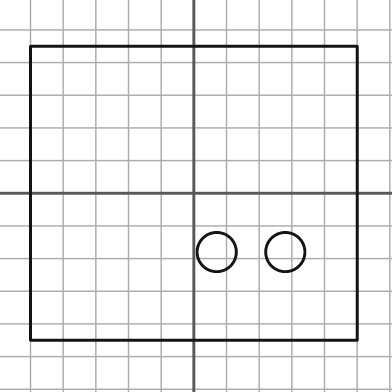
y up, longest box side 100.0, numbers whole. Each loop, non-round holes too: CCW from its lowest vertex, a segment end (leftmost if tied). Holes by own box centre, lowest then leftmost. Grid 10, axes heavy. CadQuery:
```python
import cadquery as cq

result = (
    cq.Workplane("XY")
    .moveTo(-50.0, -45.0)
    .lineTo(50.0, -45.0)
    .lineTo(50.0, 45.0)
    .lineTo(-50.0, 45.0)
    .close()
    .moveTo(7.0, -18.0)
    .circle(6.0)
    .moveTo(28.0, -18.0)
    .circle(6.0)
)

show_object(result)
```